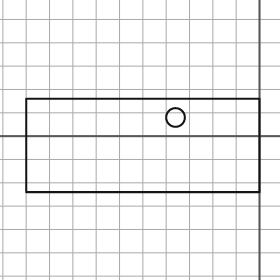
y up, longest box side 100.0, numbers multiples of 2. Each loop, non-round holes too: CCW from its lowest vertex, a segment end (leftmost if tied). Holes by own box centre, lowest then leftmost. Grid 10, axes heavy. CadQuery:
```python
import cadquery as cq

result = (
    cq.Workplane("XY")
    .moveTo(-100.0, -24.0)
    .lineTo(0.0, -24.0)
    .lineTo(0.0, 16.0)
    .lineTo(-100.0, 16.0)
    .close()
    .moveTo(-36.0, 8.0)
    .circle(4.0)
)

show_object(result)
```